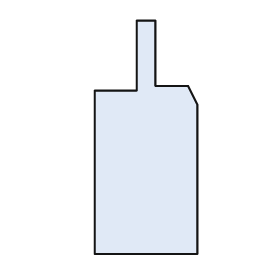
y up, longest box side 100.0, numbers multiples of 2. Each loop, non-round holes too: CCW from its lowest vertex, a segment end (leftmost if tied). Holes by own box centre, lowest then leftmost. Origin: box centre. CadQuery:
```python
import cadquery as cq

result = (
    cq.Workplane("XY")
    .moveTo(-22.0, -50.0)
    .lineTo(22.0, -50.0)
    .lineTo(22.0, 14.0)
    .lineTo(18.0, 22.0)
    .lineTo(4.0, 22.0)
    .lineTo(4.0, 50.0)
    .lineTo(-4.0, 50.0)
    .lineTo(-4.0, 20.0)
    .lineTo(-22.0, 20.0)
    .close()
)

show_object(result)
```